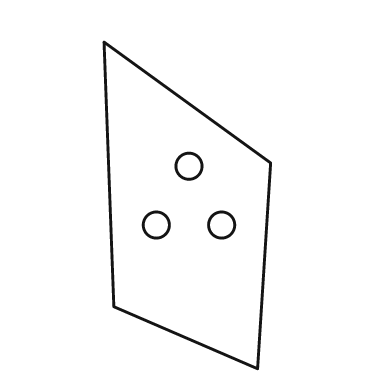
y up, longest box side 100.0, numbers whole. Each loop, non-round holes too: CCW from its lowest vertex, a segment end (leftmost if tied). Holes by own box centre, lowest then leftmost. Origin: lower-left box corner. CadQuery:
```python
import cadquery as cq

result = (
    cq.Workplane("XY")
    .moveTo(47.0, 0.0)
    .lineTo(51.0, 63.0)
    .lineTo(0.0, 100.0)
    .lineTo(3.0, 19.0)
    .close()
    .moveTo(16.0, 44.0)
    .circle(4.0)
    .moveTo(36.0, 44.0)
    .circle(4.0)
    .moveTo(26.0, 62.0)
    .circle(4.0)
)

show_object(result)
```